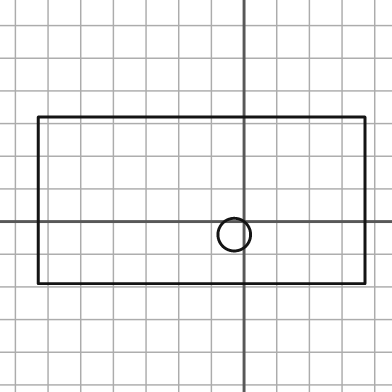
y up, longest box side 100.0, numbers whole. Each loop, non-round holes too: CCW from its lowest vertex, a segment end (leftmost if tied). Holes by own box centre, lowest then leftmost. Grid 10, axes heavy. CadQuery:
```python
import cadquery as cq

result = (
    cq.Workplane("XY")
    .moveTo(-63.0, -19.0)
    .lineTo(37.0, -19.0)
    .lineTo(37.0, 32.0)
    .lineTo(-63.0, 32.0)
    .close()
    .moveTo(-3.0, -4.0)
    .circle(5.0)
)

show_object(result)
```